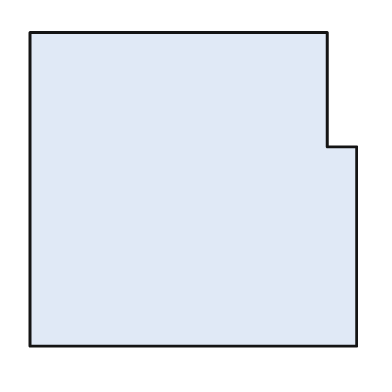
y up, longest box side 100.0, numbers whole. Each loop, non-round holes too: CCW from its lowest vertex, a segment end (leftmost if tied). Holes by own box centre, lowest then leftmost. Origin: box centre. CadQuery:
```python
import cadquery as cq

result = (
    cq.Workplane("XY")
    .moveTo(-50.0, -48.0)
    .lineTo(50.0, -48.0)
    .lineTo(50.0, 13.0)
    .lineTo(41.0, 13.0)
    .lineTo(41.0, 48.0)
    .lineTo(-50.0, 48.0)
    .close()
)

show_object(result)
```